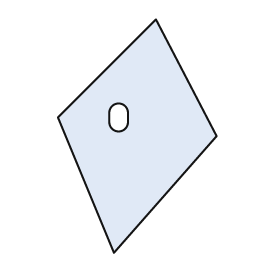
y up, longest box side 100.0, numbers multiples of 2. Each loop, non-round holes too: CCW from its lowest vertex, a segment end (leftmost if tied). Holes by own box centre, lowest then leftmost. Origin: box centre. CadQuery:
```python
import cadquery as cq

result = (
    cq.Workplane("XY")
    .moveTo(-10.0, -50.0)
    .lineTo(34.0, 0.0)
    .lineTo(8.0, 50.0)
    .lineTo(-34.0, 8.0)
    .close()
    .moveTo(-12.0, 6.0)
    .threePointArc((-8.0, 2.0), (-4.0, 6.0))
    .lineTo(-4.0, 10.0)
    .threePointArc((-8.0, 14.0), (-12.0, 10.0))
    .close()
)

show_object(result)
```